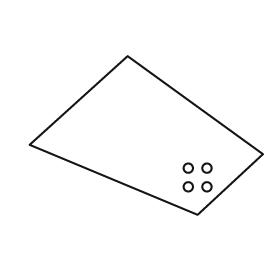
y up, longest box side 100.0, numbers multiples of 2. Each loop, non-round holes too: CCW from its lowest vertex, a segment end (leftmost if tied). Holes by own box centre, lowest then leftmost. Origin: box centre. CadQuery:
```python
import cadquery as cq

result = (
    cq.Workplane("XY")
    .moveTo(22.0, -34.0)
    .lineTo(50.0, -8.0)
    .lineTo(-8.0, 34.0)
    .lineTo(-50.0, -4.0)
    .close()
    .moveTo(18.0, -22.0)
    .circle(2.0)
    .moveTo(26.0, -22.0)
    .circle(2.0)
    .moveTo(18.0, -14.0)
    .circle(2.0)
    .moveTo(26.0, -14.0)
    .circle(2.0)
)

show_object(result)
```